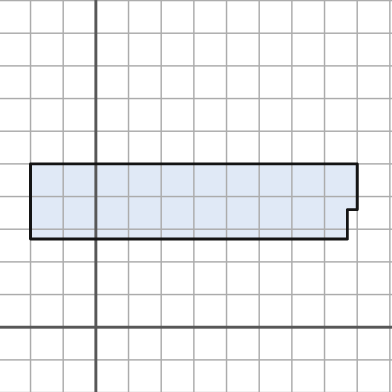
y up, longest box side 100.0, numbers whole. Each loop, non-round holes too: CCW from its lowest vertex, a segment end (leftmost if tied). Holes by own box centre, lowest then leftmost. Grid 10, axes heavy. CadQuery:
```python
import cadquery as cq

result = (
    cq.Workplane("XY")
    .moveTo(-20.0, 27.0)
    .lineTo(77.0, 27.0)
    .lineTo(77.0, 36.0)
    .lineTo(80.0, 36.0)
    .lineTo(80.0, 50.0)
    .lineTo(-20.0, 50.0)
    .close()
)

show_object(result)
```